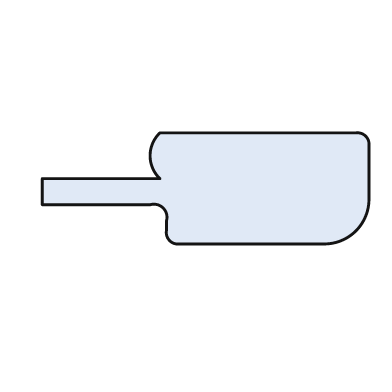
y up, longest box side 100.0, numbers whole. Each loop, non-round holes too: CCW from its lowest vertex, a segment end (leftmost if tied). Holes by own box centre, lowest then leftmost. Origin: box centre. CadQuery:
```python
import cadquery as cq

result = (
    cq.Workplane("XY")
    .moveTo(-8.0, -17.0)
    .lineTo(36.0, -17.0)
    .threePointArc((46.0, -13.0), (50.0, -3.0))
    .lineTo(50.0, 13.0)
    .threePointArc((49.0, 16.0), (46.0, 17.0))
    .lineTo(-14.0, 17.0)
    .threePointArc((-17.0, 10.0), (-14.0, 3.0))
    .lineTo(-50.0, 3.0)
    .lineTo(-50.0, -5.0)
    .lineTo(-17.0, -5.0)
    .threePointArc((-13.0, -6.0), (-12.0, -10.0))
    .lineTo(-12.0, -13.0)
    .threePointArc((-11.0, -16.0), (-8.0, -17.0))
    .close()
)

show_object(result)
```